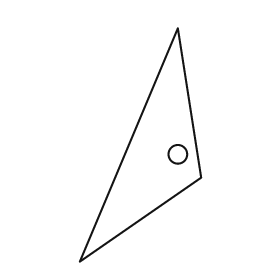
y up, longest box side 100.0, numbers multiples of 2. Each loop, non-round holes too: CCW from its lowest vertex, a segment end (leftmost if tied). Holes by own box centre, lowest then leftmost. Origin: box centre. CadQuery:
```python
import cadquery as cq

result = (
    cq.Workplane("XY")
    .moveTo(-26.0, -50.0)
    .lineTo(26.0, -14.0)
    .lineTo(16.0, 50.0)
    .close()
    .moveTo(16.0, -4.0)
    .circle(4.0)
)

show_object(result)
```